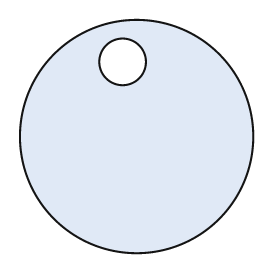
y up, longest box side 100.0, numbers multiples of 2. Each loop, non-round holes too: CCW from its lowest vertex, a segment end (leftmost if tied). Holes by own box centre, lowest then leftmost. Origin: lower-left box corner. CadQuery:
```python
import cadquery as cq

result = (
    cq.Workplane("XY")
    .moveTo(50.0, 50.0)
    .circle(50.0)
    .moveTo(44.0, 82.0)
    .circle(10.0)
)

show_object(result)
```